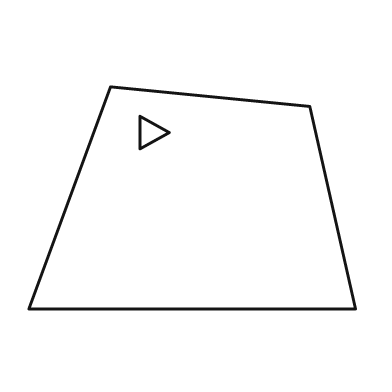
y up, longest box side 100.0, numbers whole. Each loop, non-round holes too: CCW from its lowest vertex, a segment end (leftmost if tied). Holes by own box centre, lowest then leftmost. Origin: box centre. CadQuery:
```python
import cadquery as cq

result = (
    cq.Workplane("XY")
    .moveTo(-50.0, -34.0)
    .lineTo(50.0, -34.0)
    .lineTo(36.0, 28.0)
    .lineTo(-25.0, 34.0)
    .close()
    .moveTo(-16.0, 15.0)
    .lineTo(-7.0, 20.0)
    .lineTo(-16.0, 25.0)
    .close()
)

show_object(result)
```